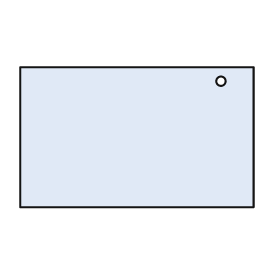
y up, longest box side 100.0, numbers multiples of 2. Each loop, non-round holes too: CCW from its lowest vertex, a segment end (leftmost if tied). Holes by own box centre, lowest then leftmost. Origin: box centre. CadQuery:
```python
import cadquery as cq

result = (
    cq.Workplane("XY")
    .moveTo(-50.0, -30.0)
    .lineTo(50.0, -30.0)
    .lineTo(50.0, 30.0)
    .lineTo(-50.0, 30.0)
    .close()
    .moveTo(36.0, 24.0)
    .circle(2.0)
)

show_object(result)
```